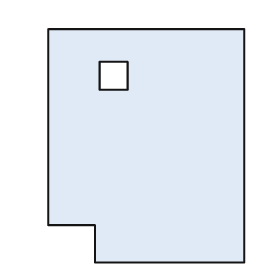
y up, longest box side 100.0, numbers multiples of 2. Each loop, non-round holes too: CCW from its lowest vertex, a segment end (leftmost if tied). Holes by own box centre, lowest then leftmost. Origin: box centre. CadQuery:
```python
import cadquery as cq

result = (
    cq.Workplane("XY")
    .moveTo(-22.0, -50.0)
    .lineTo(42.0, -50.0)
    .lineTo(42.0, 50.0)
    .lineTo(-42.0, 50.0)
    .lineTo(-42.0, -34.0)
    .lineTo(-22.0, -34.0)
    .close()
    .moveTo(-20.0, 24.0)
    .lineTo(-8.0, 24.0)
    .lineTo(-8.0, 36.0)
    .lineTo(-20.0, 36.0)
    .close()
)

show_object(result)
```